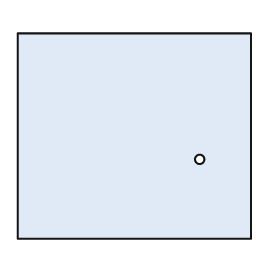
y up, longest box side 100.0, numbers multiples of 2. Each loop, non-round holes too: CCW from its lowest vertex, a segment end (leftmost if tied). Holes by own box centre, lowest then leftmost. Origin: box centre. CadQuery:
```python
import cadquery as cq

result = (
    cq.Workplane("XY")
    .moveTo(-50.0, -44.0)
    .lineTo(50.0, -44.0)
    .lineTo(50.0, 44.0)
    .lineTo(-50.0, 44.0)
    .close()
    .moveTo(28.0, -10.0)
    .circle(2.0)
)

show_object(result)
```